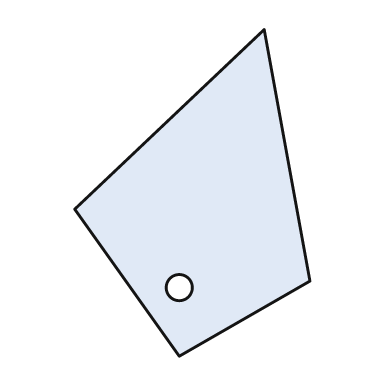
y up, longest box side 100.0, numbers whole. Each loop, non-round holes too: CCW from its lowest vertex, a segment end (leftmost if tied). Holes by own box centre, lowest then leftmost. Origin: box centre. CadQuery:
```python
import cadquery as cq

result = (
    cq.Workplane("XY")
    .moveTo(-4.0, -50.0)
    .lineTo(36.0, -27.0)
    .lineTo(22.0, 50.0)
    .lineTo(-36.0, -5.0)
    .close()
    .moveTo(-4.0, -29.0)
    .circle(4.0)
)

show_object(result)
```